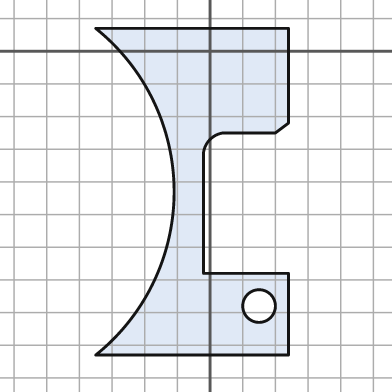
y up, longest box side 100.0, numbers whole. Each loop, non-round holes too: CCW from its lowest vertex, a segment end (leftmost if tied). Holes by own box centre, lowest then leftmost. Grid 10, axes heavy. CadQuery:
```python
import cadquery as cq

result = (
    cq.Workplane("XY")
    .moveTo(-35.0, -93.0)
    .lineTo(24.0, -93.0)
    .lineTo(24.0, -68.0)
    .lineTo(-2.0, -68.0)
    .lineTo(-2.0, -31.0)
    .threePointArc((0.0, -27.0), (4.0, -25.0))
    .lineTo(20.0, -25.0)
    .lineTo(24.0, -22.0)
    .lineTo(24.0, 7.0)
    .lineTo(-35.0, 7.0)
    .threePointArc((-11.0, -43.0), (-35.0, -93.0))
    .close()
    .moveTo(15.0, -78.0)
    .circle(5.0)
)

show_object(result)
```